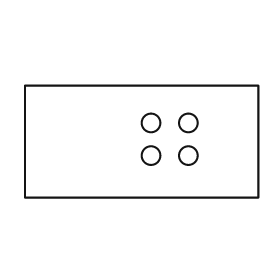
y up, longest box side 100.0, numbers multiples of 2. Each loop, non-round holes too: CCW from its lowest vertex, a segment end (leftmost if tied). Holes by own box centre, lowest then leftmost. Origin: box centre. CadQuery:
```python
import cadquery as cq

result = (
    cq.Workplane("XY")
    .moveTo(-50.0, -24.0)
    .lineTo(50.0, -24.0)
    .lineTo(50.0, 24.0)
    .lineTo(-50.0, 24.0)
    .close()
    .moveTo(4.0, -6.0)
    .circle(4.0)
    .moveTo(20.0, -6.0)
    .circle(4.0)
    .moveTo(4.0, 8.0)
    .circle(4.0)
    .moveTo(20.0, 8.0)
    .circle(4.0)
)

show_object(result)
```